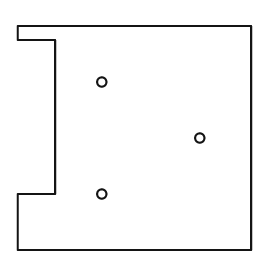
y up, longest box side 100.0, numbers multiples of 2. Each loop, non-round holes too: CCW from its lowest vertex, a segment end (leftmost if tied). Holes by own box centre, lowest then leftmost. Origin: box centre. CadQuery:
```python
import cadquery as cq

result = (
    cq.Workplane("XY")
    .moveTo(-50.0, -48.0)
    .lineTo(50.0, -48.0)
    .lineTo(50.0, 48.0)
    .lineTo(-50.0, 48.0)
    .lineTo(-50.0, 42.0)
    .lineTo(-34.0, 42.0)
    .lineTo(-34.0, -24.0)
    .lineTo(-50.0, -24.0)
    .close()
    .moveTo(-14.0, -24.0)
    .circle(2.0)
    .moveTo(28.0, 0.0)
    .circle(2.0)
    .moveTo(-14.0, 24.0)
    .circle(2.0)
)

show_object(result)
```